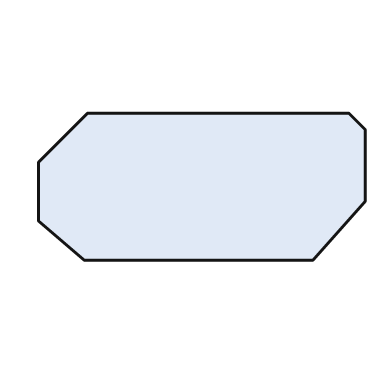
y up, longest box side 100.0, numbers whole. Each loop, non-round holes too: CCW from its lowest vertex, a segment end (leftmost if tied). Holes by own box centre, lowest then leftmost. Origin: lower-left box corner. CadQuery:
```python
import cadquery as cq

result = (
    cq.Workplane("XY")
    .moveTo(14.0, 0.0)
    .lineTo(84.0, 0.0)
    .lineTo(100.0, 18.0)
    .lineTo(100.0, 40.0)
    .lineTo(95.0, 45.0)
    .lineTo(15.0, 45.0)
    .lineTo(0.0, 30.0)
    .lineTo(0.0, 12.0)
    .close()
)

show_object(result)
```